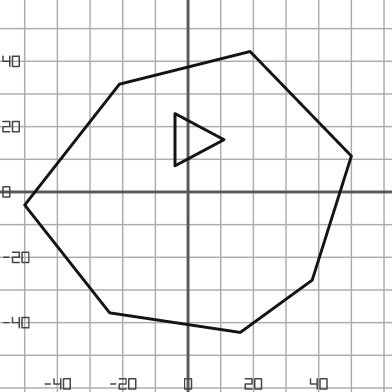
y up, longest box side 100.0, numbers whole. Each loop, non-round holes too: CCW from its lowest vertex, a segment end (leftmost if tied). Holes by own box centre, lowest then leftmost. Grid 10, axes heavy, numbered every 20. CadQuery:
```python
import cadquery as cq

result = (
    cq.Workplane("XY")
    .moveTo(16.0, -43.0)
    .lineTo(38.0, -27.0)
    .lineTo(50.0, 11.0)
    .lineTo(19.0, 43.0)
    .lineTo(-21.0, 33.0)
    .lineTo(-50.0, -4.0)
    .lineTo(-24.0, -37.0)
    .close()
    .moveTo(-4.0, 8.0)
    .lineTo(11.0, 16.0)
    .lineTo(-4.0, 24.0)
    .close()
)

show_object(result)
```